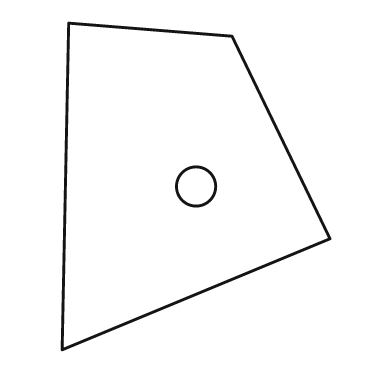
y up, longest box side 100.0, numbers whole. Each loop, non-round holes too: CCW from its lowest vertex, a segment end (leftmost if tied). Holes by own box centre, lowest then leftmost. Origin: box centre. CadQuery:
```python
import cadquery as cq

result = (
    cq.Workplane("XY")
    .moveTo(-41.0, -50.0)
    .lineTo(41.0, -16.0)
    .lineTo(11.0, 46.0)
    .lineTo(-39.0, 50.0)
    .close()
    .moveTo(0.0, 0.0)
    .circle(6.0)
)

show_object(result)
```